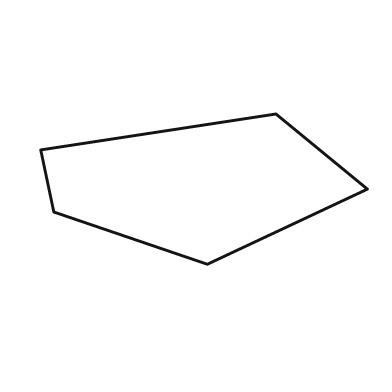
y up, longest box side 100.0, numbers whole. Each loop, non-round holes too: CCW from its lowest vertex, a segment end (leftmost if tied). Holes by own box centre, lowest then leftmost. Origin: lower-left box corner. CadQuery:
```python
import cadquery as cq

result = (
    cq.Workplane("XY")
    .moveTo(51.0, 0.0)
    .lineTo(100.0, 23.0)
    .lineTo(72.0, 46.0)
    .lineTo(0.0, 35.0)
    .lineTo(4.0, 16.0)
    .close()
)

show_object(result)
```